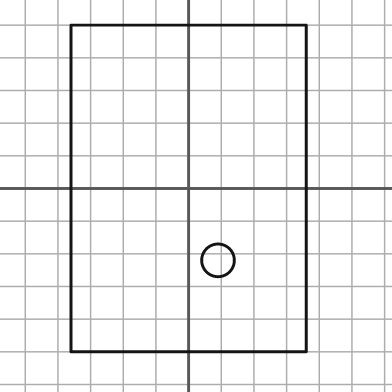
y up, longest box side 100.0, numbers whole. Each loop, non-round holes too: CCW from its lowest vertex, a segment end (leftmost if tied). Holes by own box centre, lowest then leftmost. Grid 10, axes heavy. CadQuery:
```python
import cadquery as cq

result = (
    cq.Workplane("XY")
    .moveTo(-36.0, -50.0)
    .lineTo(36.0, -50.0)
    .lineTo(36.0, 50.0)
    .lineTo(-36.0, 50.0)
    .close()
    .moveTo(9.0, -22.0)
    .circle(5.0)
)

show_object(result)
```